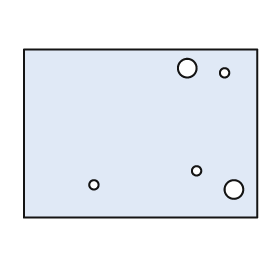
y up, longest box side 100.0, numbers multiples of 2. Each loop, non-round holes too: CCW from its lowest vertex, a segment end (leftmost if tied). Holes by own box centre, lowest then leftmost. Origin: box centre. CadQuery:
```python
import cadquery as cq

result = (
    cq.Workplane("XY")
    .moveTo(-50.0, -36.0)
    .lineTo(50.0, -36.0)
    .lineTo(50.0, 36.0)
    .lineTo(-50.0, 36.0)
    .close()
    .moveTo(40.0, -24.0)
    .circle(4.0)
    .moveTo(-20.0, -22.0)
    .circle(2.0)
    .moveTo(24.0, -16.0)
    .circle(2.0)
    .moveTo(36.0, 26.0)
    .circle(2.0)
    .moveTo(20.0, 28.0)
    .circle(4.0)
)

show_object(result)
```